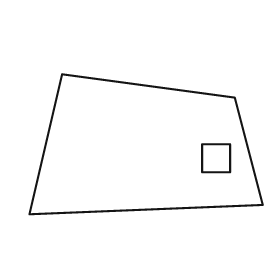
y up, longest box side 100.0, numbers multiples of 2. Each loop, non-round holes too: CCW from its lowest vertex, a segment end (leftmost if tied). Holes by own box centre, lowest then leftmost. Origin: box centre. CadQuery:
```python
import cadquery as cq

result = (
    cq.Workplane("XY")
    .moveTo(-50.0, -30.0)
    .lineTo(50.0, -26.0)
    .lineTo(38.0, 20.0)
    .lineTo(-36.0, 30.0)
    .close()
    .moveTo(24.0, -12.0)
    .lineTo(36.0, -12.0)
    .lineTo(36.0, 0.0)
    .lineTo(24.0, 0.0)
    .close()
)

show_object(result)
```